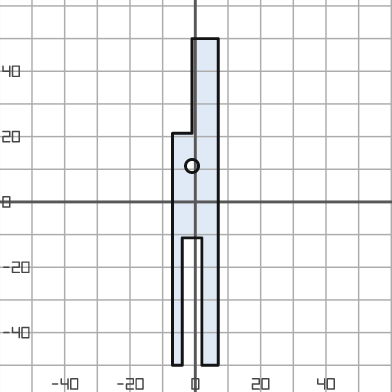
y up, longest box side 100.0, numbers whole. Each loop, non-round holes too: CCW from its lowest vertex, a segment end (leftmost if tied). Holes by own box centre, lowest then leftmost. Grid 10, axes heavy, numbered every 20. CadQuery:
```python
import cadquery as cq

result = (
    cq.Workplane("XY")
    .moveTo(-7.0, -50.0)
    .lineTo(-4.0, -50.0)
    .lineTo(-4.0, -11.0)
    .lineTo(2.0, -11.0)
    .lineTo(2.0, -50.0)
    .lineTo(7.0, -50.0)
    .lineTo(7.0, 50.0)
    .lineTo(-1.0, 50.0)
    .lineTo(-1.0, 21.0)
    .lineTo(-7.0, 21.0)
    .close()
    .moveTo(-1.0, 11.0)
    .circle(2.0)
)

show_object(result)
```